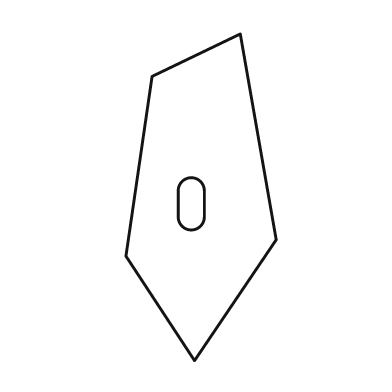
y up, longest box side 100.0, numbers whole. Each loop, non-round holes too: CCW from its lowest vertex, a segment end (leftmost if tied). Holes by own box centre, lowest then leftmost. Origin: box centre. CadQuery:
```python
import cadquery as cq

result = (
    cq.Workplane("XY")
    .moveTo(-2.0, -50.0)
    .lineTo(23.0, -13.0)
    .lineTo(12.0, 50.0)
    .lineTo(-15.0, 37.0)
    .lineTo(-23.0, -18.0)
    .close()
    .moveTo(-7.0, -6.0)
    .threePointArc((-3.0, -10.0), (1.0, -6.0))
    .lineTo(1.0, 2.0)
    .threePointArc((-3.0, 6.0), (-7.0, 2.0))
    .close()
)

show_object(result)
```